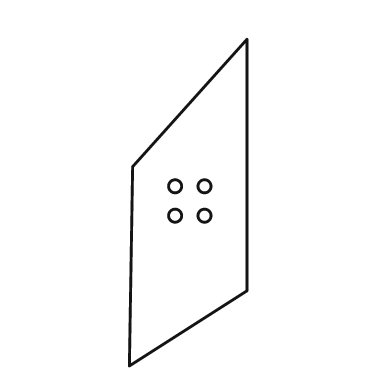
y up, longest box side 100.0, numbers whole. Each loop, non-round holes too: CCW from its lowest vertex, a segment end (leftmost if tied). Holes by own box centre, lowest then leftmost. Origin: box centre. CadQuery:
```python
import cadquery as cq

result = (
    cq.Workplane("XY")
    .moveTo(-18.0, -50.0)
    .lineTo(18.0, -27.0)
    .lineTo(18.0, 50.0)
    .lineTo(-17.0, 11.0)
    .close()
    .moveTo(-4.0, -4.0)
    .circle(2.0)
    .moveTo(5.0, -4.0)
    .circle(2.0)
    .moveTo(-4.0, 5.0)
    .circle(2.0)
    .moveTo(5.0, 5.0)
    .circle(2.0)
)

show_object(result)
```